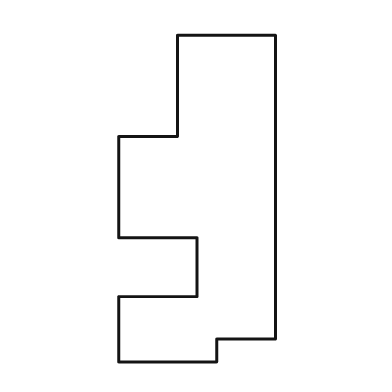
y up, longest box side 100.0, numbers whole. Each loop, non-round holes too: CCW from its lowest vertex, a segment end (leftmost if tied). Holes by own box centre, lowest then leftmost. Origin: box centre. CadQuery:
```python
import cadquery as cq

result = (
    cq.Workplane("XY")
    .moveTo(-24.0, -50.0)
    .lineTo(6.0, -50.0)
    .lineTo(6.0, -43.0)
    .lineTo(24.0, -43.0)
    .lineTo(24.0, 50.0)
    .lineTo(-6.0, 50.0)
    .lineTo(-6.0, 19.0)
    .lineTo(-24.0, 19.0)
    .lineTo(-24.0, -12.0)
    .lineTo(0.0, -12.0)
    .lineTo(0.0, -30.0)
    .lineTo(-24.0, -30.0)
    .close()
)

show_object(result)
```